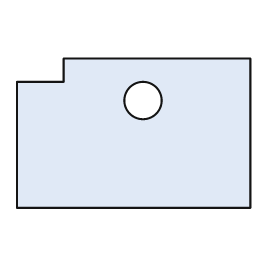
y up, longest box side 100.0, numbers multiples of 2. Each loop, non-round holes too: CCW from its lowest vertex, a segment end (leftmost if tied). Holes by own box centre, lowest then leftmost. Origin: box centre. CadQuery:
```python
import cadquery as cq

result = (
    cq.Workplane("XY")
    .moveTo(-50.0, -32.0)
    .lineTo(50.0, -32.0)
    .lineTo(50.0, 32.0)
    .lineTo(-30.0, 32.0)
    .lineTo(-30.0, 22.0)
    .lineTo(-50.0, 22.0)
    .close()
    .moveTo(4.0, 14.0)
    .circle(8.0)
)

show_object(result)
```